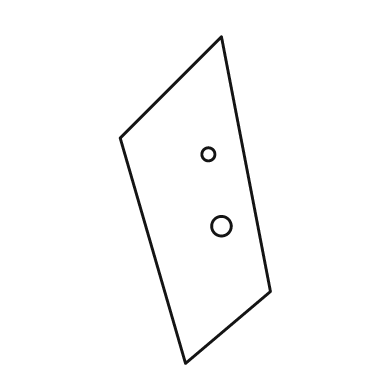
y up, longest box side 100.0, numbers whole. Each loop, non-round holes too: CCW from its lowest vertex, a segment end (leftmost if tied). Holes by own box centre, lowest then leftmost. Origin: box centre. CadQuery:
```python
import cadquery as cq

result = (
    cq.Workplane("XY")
    .moveTo(-3.0, -50.0)
    .lineTo(23.0, -28.0)
    .lineTo(8.0, 50.0)
    .lineTo(-23.0, 19.0)
    .close()
    .moveTo(8.0, -8.0)
    .circle(3.0)
    .moveTo(4.0, 14.0)
    .circle(2.0)
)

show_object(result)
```